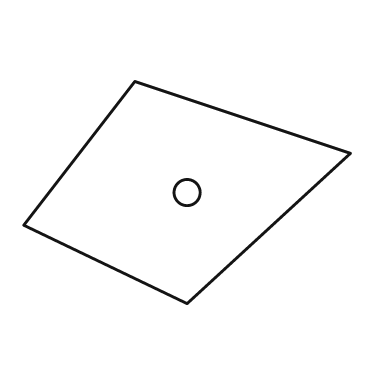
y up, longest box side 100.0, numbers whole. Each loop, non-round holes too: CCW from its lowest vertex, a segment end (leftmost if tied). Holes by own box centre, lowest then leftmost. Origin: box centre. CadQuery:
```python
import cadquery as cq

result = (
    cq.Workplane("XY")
    .moveTo(0.0, -34.0)
    .lineTo(50.0, 12.0)
    .lineTo(-16.0, 34.0)
    .lineTo(-50.0, -10.0)
    .close()
    .moveTo(0.0, 0.0)
    .circle(4.0)
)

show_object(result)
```